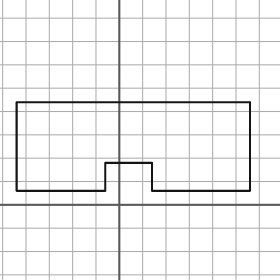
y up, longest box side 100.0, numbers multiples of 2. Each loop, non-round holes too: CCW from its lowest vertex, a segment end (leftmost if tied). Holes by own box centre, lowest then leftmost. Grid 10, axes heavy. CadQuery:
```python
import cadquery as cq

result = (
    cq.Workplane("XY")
    .moveTo(-44.0, 6.0)
    .lineTo(-6.0, 6.0)
    .lineTo(-6.0, 18.0)
    .lineTo(14.0, 18.0)
    .lineTo(14.0, 6.0)
    .lineTo(56.0, 6.0)
    .lineTo(56.0, 44.0)
    .lineTo(-44.0, 44.0)
    .close()
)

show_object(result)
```